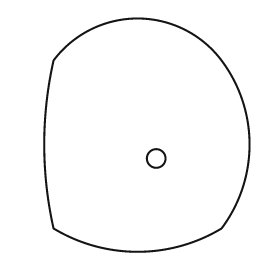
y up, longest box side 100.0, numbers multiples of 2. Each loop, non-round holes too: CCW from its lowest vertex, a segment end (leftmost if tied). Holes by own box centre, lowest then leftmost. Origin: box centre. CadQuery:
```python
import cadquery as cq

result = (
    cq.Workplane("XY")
    .moveTo(-40.0, -40.0)
    .threePointArc((-4.0, -50.0), (32.0, -40.0))
    .threePointArc((44.0, -4.0), (32.0, 32.0))
    .threePointArc((-4.0, 50.0), (-40.0, 32.0))
    .threePointArc((-44.0, -4.0), (-40.0, -40.0))
    .close()
    .moveTo(4.0, -10.0)
    .circle(4.0)
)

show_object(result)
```